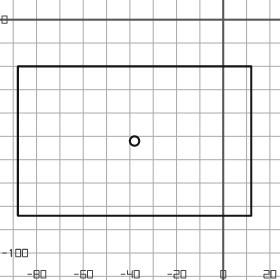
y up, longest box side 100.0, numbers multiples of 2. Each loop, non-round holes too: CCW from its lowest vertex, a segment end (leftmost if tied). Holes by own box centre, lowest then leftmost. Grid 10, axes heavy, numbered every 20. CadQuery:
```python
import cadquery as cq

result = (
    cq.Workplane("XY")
    .moveTo(-88.0, -84.0)
    .lineTo(12.0, -84.0)
    .lineTo(12.0, -20.0)
    .lineTo(-88.0, -20.0)
    .close()
    .moveTo(-38.0, -52.0)
    .circle(2.0)
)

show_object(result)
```